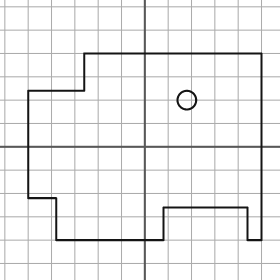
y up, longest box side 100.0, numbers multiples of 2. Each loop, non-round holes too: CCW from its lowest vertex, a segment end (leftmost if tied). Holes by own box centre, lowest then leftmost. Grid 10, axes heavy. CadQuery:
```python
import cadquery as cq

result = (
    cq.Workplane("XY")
    .moveTo(-38.0, -40.0)
    .lineTo(8.0, -40.0)
    .lineTo(8.0, -26.0)
    .lineTo(44.0, -26.0)
    .lineTo(44.0, -40.0)
    .lineTo(50.0, -40.0)
    .lineTo(50.0, 40.0)
    .lineTo(-26.0, 40.0)
    .lineTo(-26.0, 24.0)
    .lineTo(-50.0, 24.0)
    .lineTo(-50.0, -22.0)
    .lineTo(-38.0, -22.0)
    .close()
    .moveTo(18.0, 20.0)
    .circle(4.0)
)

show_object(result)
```